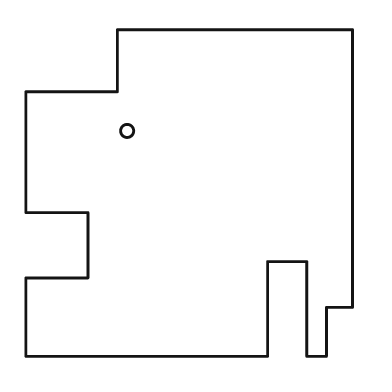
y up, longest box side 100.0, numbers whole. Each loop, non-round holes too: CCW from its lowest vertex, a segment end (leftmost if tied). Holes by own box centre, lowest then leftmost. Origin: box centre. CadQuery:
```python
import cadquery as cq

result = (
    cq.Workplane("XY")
    .moveTo(-50.0, -50.0)
    .lineTo(24.0, -50.0)
    .lineTo(24.0, -21.0)
    .lineTo(36.0, -21.0)
    .lineTo(36.0, -50.0)
    .lineTo(42.0, -50.0)
    .lineTo(42.0, -35.0)
    .lineTo(50.0, -35.0)
    .lineTo(50.0, 50.0)
    .lineTo(-22.0, 50.0)
    .lineTo(-22.0, 31.0)
    .lineTo(-50.0, 31.0)
    .lineTo(-50.0, -6.0)
    .lineTo(-31.0, -6.0)
    .lineTo(-31.0, -26.0)
    .lineTo(-50.0, -26.0)
    .close()
    .moveTo(-19.0, 19.0)
    .circle(2.0)
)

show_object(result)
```